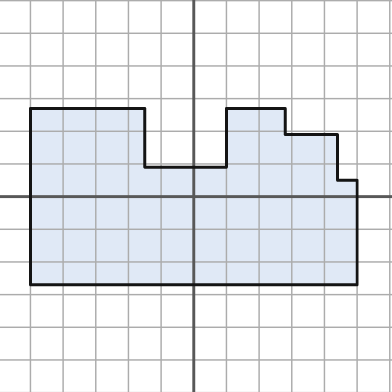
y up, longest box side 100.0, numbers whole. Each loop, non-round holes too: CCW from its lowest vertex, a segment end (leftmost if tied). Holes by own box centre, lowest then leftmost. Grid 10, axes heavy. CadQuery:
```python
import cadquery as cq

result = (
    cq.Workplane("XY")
    .moveTo(-50.0, -27.0)
    .lineTo(50.0, -27.0)
    .lineTo(50.0, 5.0)
    .lineTo(44.0, 5.0)
    .lineTo(44.0, 19.0)
    .lineTo(28.0, 19.0)
    .lineTo(28.0, 27.0)
    .lineTo(10.0, 27.0)
    .lineTo(10.0, 9.0)
    .lineTo(-15.0, 9.0)
    .lineTo(-15.0, 27.0)
    .lineTo(-50.0, 27.0)
    .close()
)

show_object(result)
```